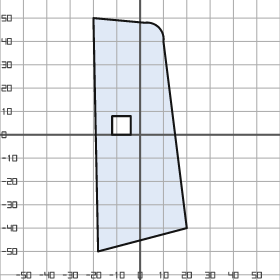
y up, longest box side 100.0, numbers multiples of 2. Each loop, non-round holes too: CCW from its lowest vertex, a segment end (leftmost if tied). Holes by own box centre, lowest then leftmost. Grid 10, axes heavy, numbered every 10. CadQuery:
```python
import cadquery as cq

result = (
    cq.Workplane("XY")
    .moveTo(-18.0, -50.0)
    .lineTo(20.0, -40.0)
    .lineTo(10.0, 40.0)
    .threePointArc((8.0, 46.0), (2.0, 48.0))
    .lineTo(-20.0, 50.0)
    .close()
    .moveTo(-12.0, 0.0)
    .lineTo(-4.0, 0.0)
    .lineTo(-4.0, 8.0)
    .lineTo(-12.0, 8.0)
    .close()
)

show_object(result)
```